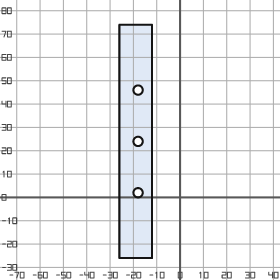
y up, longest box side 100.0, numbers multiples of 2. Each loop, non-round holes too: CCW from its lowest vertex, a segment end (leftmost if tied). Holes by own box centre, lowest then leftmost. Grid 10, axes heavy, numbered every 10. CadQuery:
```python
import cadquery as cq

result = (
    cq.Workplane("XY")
    .moveTo(-26.0, -26.0)
    .lineTo(-12.0, -26.0)
    .lineTo(-12.0, 74.0)
    .lineTo(-26.0, 74.0)
    .close()
    .moveTo(-18.0, 2.0)
    .circle(2.0)
    .moveTo(-18.0, 24.0)
    .circle(2.0)
    .moveTo(-18.0, 46.0)
    .circle(2.0)
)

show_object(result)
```